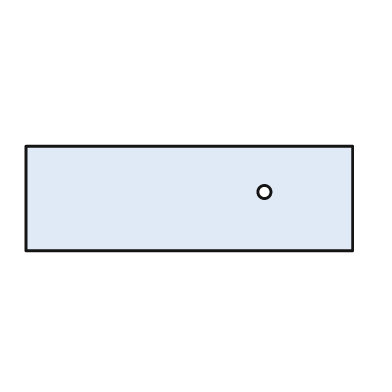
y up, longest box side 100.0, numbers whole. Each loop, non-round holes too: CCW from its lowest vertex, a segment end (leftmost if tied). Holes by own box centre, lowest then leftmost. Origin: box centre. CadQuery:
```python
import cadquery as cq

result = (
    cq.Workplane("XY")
    .moveTo(-50.0, -16.0)
    .lineTo(50.0, -16.0)
    .lineTo(50.0, 16.0)
    .lineTo(-50.0, 16.0)
    .close()
    .moveTo(23.0, 2.0)
    .circle(2.0)
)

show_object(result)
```